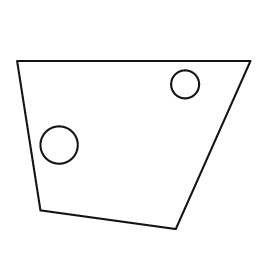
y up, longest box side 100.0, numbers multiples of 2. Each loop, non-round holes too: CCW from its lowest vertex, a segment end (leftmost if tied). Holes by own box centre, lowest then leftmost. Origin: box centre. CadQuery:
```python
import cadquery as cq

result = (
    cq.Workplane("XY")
    .moveTo(18.0, -36.0)
    .lineTo(50.0, 36.0)
    .lineTo(-50.0, 36.0)
    .lineTo(-40.0, -28.0)
    .close()
    .moveTo(-32.0, 0.0)
    .circle(8.0)
    .moveTo(22.0, 26.0)
    .circle(6.0)
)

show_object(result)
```